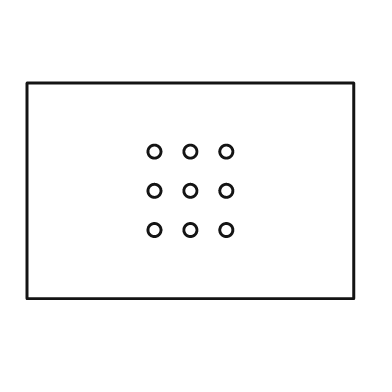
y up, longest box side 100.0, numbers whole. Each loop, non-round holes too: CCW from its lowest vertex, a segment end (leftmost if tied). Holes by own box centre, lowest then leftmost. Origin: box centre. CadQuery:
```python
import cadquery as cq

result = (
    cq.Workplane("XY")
    .moveTo(-50.0, -33.0)
    .lineTo(50.0, -33.0)
    .lineTo(50.0, 33.0)
    .lineTo(-50.0, 33.0)
    .close()
    .moveTo(-11.0, -12.0)
    .circle(2.0)
    .moveTo(0.0, -12.0)
    .circle(2.0)
    .moveTo(11.0, -12.0)
    .circle(2.0)
    .moveTo(-11.0, 0.0)
    .circle(2.0)
    .moveTo(0.0, 0.0)
    .circle(2.0)
    .moveTo(11.0, 0.0)
    .circle(2.0)
    .moveTo(-11.0, 12.0)
    .circle(2.0)
    .moveTo(0.0, 12.0)
    .circle(2.0)
    .moveTo(11.0, 12.0)
    .circle(2.0)
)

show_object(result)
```